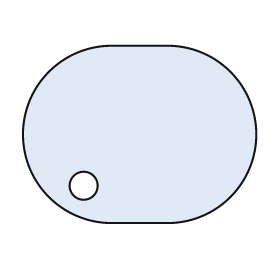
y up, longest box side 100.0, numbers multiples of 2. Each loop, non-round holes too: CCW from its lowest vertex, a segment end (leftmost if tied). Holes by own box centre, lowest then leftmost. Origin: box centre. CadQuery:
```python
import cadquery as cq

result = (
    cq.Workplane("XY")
    .moveTo(-12.0, -38.0)
    .lineTo(12.0, -38.0)
    .threePointArc((50.0, 0.0), (12.0, 38.0))
    .lineTo(-12.0, 38.0)
    .threePointArc((-50.0, 0.0), (-12.0, -38.0))
    .close()
    .moveTo(-24.0, -22.0)
    .circle(6.0)
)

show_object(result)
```